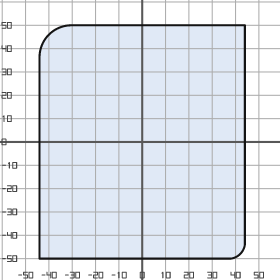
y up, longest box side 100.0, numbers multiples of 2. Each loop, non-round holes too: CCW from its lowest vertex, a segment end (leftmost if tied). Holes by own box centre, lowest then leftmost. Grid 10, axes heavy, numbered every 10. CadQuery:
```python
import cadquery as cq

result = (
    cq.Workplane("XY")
    .moveTo(-44.0, -50.0)
    .lineTo(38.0, -50.0)
    .threePointArc((42.0, -48.0), (44.0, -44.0))
    .lineTo(44.0, 50.0)
    .lineTo(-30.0, 50.0)
    .threePointArc((-40.0, 46.0), (-44.0, 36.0))
    .close()
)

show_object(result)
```